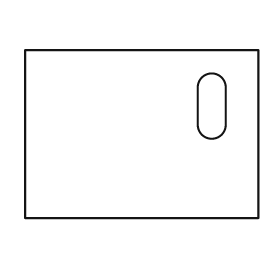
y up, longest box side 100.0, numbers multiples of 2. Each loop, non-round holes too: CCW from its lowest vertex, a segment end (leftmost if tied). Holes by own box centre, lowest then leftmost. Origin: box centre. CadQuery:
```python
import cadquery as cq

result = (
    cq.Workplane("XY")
    .moveTo(-50.0, -36.0)
    .lineTo(50.0, -36.0)
    .lineTo(50.0, 36.0)
    .lineTo(-50.0, 36.0)
    .close()
    .moveTo(24.0, 4.0)
    .threePointArc((30.0, -2.0), (36.0, 4.0))
    .lineTo(36.0, 20.0)
    .threePointArc((30.0, 26.0), (24.0, 20.0))
    .close()
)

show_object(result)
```